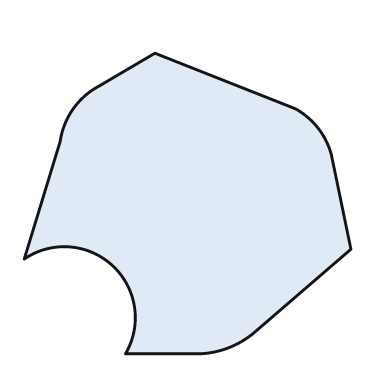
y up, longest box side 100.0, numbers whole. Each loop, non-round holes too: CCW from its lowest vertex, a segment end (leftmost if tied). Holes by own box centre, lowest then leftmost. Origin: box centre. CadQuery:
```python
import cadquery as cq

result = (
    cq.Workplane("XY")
    .moveTo(-19.0, -46.0)
    .lineTo(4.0, -46.0)
    .threePointArc((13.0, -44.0), (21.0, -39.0))
    .lineTo(50.0, -14.0)
    .lineTo(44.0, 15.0)
    .threePointArc((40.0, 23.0), (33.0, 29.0))
    .lineTo(-10.0, 46.0)
    .lineTo(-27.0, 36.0)
    .threePointArc((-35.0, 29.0), (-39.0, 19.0))
    .lineTo(-50.0, -17.0)
    .threePointArc((-23.0, -19.0), (-19.0, -46.0))
    .close()
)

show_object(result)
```